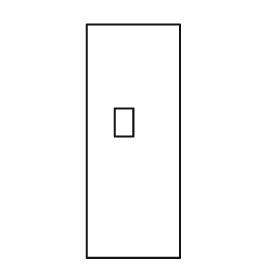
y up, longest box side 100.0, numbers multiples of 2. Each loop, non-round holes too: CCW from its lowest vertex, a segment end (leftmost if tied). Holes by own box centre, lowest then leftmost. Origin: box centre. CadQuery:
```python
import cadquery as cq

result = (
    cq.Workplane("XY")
    .moveTo(-20.0, -50.0)
    .lineTo(20.0, -50.0)
    .lineTo(20.0, 50.0)
    .lineTo(-20.0, 50.0)
    .close()
    .moveTo(-8.0, 2.0)
    .lineTo(0.0, 2.0)
    .lineTo(0.0, 14.0)
    .lineTo(-8.0, 14.0)
    .close()
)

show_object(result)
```